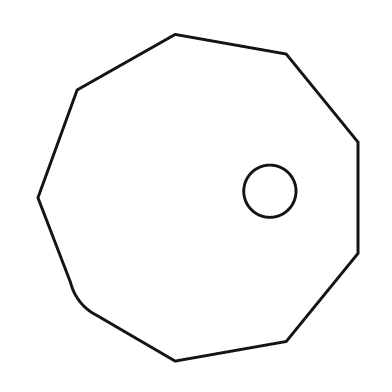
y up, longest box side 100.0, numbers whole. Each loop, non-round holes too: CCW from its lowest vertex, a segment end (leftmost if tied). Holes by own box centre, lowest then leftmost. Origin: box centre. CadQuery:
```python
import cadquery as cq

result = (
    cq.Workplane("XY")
    .moveTo(-7.0, -50.0)
    .lineTo(27.0, -44.0)
    .lineTo(49.0, -17.0)
    .lineTo(49.0, 17.0)
    .lineTo(27.0, 44.0)
    .lineTo(-7.0, 50.0)
    .lineTo(-37.0, 33.0)
    .lineTo(-49.0, 0.0)
    .lineTo(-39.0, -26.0)
    .threePointArc((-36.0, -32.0), (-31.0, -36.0))
    .close()
    .moveTo(22.0, 2.0)
    .circle(8.0)
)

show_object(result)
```